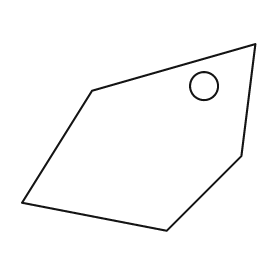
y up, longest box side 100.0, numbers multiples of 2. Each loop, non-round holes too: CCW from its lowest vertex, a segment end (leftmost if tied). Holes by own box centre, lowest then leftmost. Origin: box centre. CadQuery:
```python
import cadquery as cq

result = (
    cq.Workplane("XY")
    .moveTo(12.0, -40.0)
    .lineTo(44.0, -8.0)
    .lineTo(50.0, 40.0)
    .lineTo(-20.0, 20.0)
    .lineTo(-50.0, -28.0)
    .close()
    .moveTo(28.0, 22.0)
    .circle(6.0)
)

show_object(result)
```